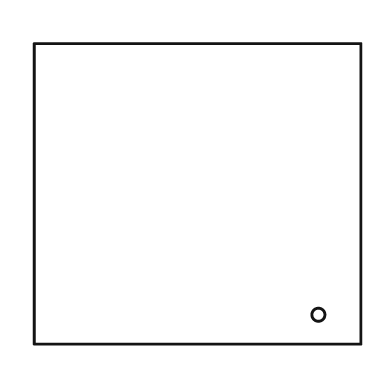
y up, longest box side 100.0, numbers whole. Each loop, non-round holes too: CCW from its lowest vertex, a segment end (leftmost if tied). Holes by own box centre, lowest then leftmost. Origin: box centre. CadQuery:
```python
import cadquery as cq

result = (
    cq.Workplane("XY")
    .moveTo(-50.0, -46.0)
    .lineTo(50.0, -46.0)
    .lineTo(50.0, 46.0)
    .lineTo(-50.0, 46.0)
    .close()
    .moveTo(37.0, -37.0)
    .circle(2.0)
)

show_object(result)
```